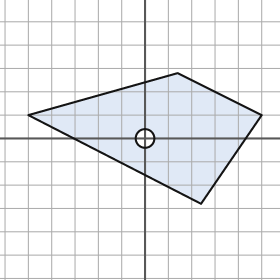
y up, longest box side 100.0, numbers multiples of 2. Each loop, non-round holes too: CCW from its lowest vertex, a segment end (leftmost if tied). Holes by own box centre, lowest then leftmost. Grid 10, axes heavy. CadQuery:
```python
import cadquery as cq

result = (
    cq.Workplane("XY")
    .moveTo(24.0, -28.0)
    .lineTo(50.0, 10.0)
    .lineTo(14.0, 28.0)
    .lineTo(-50.0, 10.0)
    .close()
    .moveTo(0.0, 0.0)
    .circle(4.0)
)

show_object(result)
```